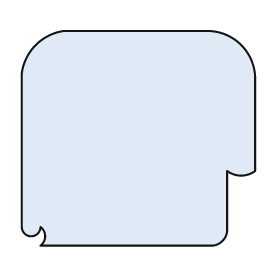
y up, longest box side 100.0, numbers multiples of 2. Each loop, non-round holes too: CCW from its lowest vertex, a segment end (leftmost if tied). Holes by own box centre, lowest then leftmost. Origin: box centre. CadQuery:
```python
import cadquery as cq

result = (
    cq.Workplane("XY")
    .moveTo(-42.0, -46.0)
    .lineTo(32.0, -46.0)
    .threePointArc((36.0, -44.0), (38.0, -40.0))
    .lineTo(38.0, -14.0)
    .threePointArc((44.0, -16.0), (50.0, -14.0))
    .lineTo(50.0, 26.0)
    .threePointArc((44.0, 40.0), (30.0, 46.0))
    .lineTo(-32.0, 46.0)
    .threePointArc((-44.0, 40.0), (-50.0, 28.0))
    .lineTo(-50.0, -38.0)
    .threePointArc((-46.0, -42.0), (-42.0, -38.0))
    .threePointArc((-40.0, -42.0), (-42.0, -46.0))
    .close()
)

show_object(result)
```